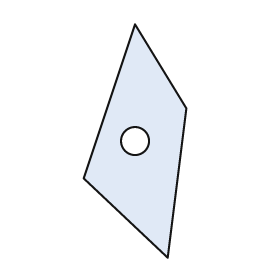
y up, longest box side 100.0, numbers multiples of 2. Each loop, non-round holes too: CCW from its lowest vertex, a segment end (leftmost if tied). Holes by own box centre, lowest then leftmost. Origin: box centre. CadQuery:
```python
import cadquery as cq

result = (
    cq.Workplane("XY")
    .moveTo(14.0, -50.0)
    .lineTo(22.0, 14.0)
    .lineTo(0.0, 50.0)
    .lineTo(-22.0, -16.0)
    .close()
    .moveTo(0.0, 0.0)
    .circle(6.0)
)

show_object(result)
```